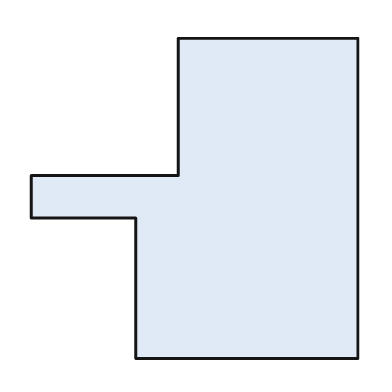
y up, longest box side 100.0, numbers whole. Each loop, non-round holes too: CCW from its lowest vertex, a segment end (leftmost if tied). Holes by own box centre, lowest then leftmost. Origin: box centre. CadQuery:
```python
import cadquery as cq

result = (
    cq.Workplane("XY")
    .moveTo(-18.0, -49.0)
    .lineTo(50.0, -49.0)
    .lineTo(50.0, 49.0)
    .lineTo(-5.0, 49.0)
    .lineTo(-5.0, 7.0)
    .lineTo(-50.0, 7.0)
    .lineTo(-50.0, -6.0)
    .lineTo(-18.0, -6.0)
    .close()
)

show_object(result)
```